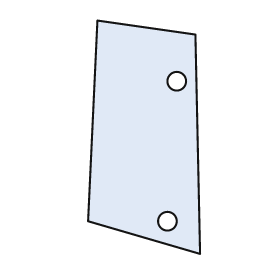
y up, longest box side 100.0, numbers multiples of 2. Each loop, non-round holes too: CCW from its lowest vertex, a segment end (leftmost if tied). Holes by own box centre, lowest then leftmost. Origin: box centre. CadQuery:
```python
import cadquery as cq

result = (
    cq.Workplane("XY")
    .moveTo(24.0, -50.0)
    .lineTo(22.0, 44.0)
    .lineTo(-20.0, 50.0)
    .lineTo(-24.0, -36.0)
    .close()
    .moveTo(10.0, -36.0)
    .circle(4.0)
    .moveTo(14.0, 24.0)
    .circle(4.0)
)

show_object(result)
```